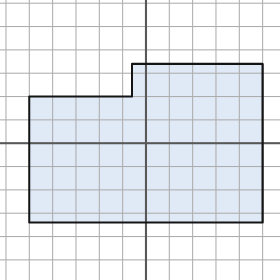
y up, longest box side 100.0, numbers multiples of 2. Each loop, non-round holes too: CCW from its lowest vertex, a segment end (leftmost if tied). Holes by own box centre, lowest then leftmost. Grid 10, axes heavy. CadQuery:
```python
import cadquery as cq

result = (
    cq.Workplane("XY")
    .moveTo(-50.0, -34.0)
    .lineTo(50.0, -34.0)
    .lineTo(50.0, 34.0)
    .lineTo(-6.0, 34.0)
    .lineTo(-6.0, 20.0)
    .lineTo(-50.0, 20.0)
    .close()
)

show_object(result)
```